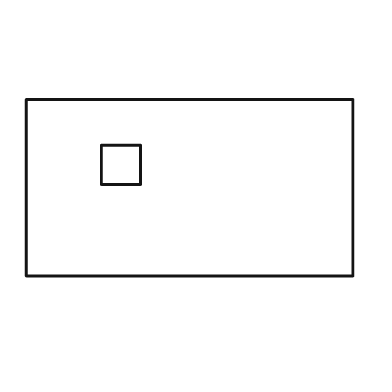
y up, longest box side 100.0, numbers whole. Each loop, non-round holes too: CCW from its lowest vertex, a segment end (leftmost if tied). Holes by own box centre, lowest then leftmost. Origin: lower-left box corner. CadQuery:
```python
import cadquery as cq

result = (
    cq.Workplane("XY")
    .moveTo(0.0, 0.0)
    .lineTo(100.0, 0.0)
    .lineTo(100.0, 54.0)
    .lineTo(0.0, 54.0)
    .close()
    .moveTo(23.0, 28.0)
    .lineTo(35.0, 28.0)
    .lineTo(35.0, 40.0)
    .lineTo(23.0, 40.0)
    .close()
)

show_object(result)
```